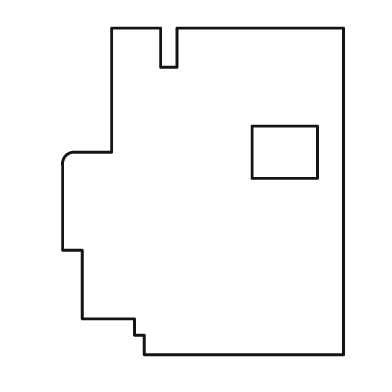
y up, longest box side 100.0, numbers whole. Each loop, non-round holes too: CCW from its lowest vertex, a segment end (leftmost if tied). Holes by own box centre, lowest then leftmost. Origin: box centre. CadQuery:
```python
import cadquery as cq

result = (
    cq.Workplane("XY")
    .moveTo(-18.0, -50.0)
    .lineTo(43.0, -50.0)
    .lineTo(43.0, 50.0)
    .lineTo(-8.0, 50.0)
    .lineTo(-8.0, 38.0)
    .lineTo(-13.0, 38.0)
    .lineTo(-13.0, 50.0)
    .lineTo(-28.0, 50.0)
    .lineTo(-28.0, 12.0)
    .lineTo(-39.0, 12.0)
    .threePointArc((-42.0, 11.0), (-43.0, 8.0))
    .lineTo(-43.0, -18.0)
    .lineTo(-37.0, -18.0)
    .lineTo(-37.0, -39.0)
    .lineTo(-21.0, -39.0)
    .lineTo(-21.0, -44.0)
    .lineTo(-18.0, -44.0)
    .close()
    .moveTo(15.0, 4.0)
    .lineTo(35.0, 4.0)
    .lineTo(35.0, 20.0)
    .lineTo(15.0, 20.0)
    .close()
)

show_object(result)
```